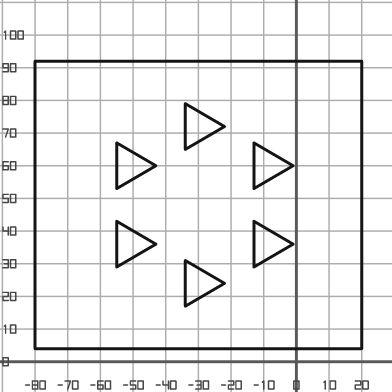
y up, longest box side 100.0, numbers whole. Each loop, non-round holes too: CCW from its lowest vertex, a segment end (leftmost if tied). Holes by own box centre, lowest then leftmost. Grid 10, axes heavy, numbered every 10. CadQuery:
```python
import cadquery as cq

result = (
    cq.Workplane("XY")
    .moveTo(-80.0, 4.0)
    .lineTo(20.0, 4.0)
    .lineTo(20.0, 92.0)
    .lineTo(-80.0, 92.0)
    .close()
    .moveTo(-34.0, 17.0)
    .lineTo(-22.0, 24.0)
    .lineTo(-34.0, 31.0)
    .close()
    .moveTo(-55.0, 29.0)
    .lineTo(-43.0, 36.0)
    .lineTo(-55.0, 43.0)
    .close()
    .moveTo(-13.0, 29.0)
    .lineTo(-1.0, 36.0)
    .lineTo(-13.0, 43.0)
    .close()
    .moveTo(-55.0, 53.0)
    .lineTo(-43.0, 60.0)
    .lineTo(-55.0, 67.0)
    .close()
    .moveTo(-13.0, 53.0)
    .lineTo(-1.0, 60.0)
    .lineTo(-13.0, 67.0)
    .close()
    .moveTo(-34.0, 65.0)
    .lineTo(-22.0, 72.0)
    .lineTo(-34.0, 79.0)
    .close()
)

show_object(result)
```